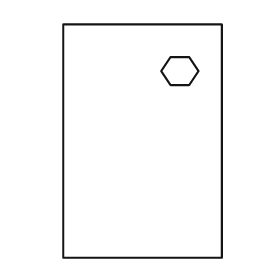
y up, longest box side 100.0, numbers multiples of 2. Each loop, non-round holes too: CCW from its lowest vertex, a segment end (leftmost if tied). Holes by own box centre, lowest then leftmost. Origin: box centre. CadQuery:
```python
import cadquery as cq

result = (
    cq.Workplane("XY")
    .moveTo(-34.0, -50.0)
    .lineTo(34.0, -50.0)
    .lineTo(34.0, 50.0)
    .lineTo(-34.0, 50.0)
    .close()
    .moveTo(12.0, 24.0)
    .lineTo(20.0, 24.0)
    .lineTo(24.0, 30.0)
    .lineTo(20.0, 36.0)
    .lineTo(12.0, 36.0)
    .lineTo(8.0, 30.0)
    .close()
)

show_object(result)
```